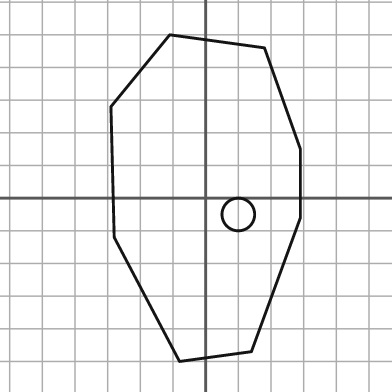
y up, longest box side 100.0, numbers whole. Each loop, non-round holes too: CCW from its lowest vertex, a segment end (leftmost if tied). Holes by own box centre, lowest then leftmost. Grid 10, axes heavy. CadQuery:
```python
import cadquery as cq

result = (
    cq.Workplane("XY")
    .moveTo(-8.0, -50.0)
    .lineTo(14.0, -47.0)
    .lineTo(29.0, -6.0)
    .lineTo(29.0, 15.0)
    .lineTo(18.0, 46.0)
    .lineTo(-11.0, 50.0)
    .lineTo(-29.0, 28.0)
    .lineTo(-28.0, -12.0)
    .close()
    .moveTo(10.0, -5.0)
    .circle(5.0)
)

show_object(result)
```